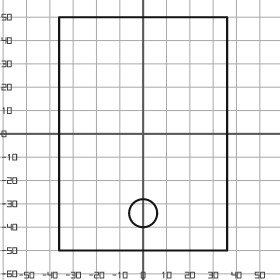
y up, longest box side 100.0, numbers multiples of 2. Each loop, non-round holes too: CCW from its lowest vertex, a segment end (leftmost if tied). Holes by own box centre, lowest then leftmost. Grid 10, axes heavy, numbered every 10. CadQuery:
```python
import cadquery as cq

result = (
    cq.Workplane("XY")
    .moveTo(-36.0, -50.0)
    .lineTo(36.0, -50.0)
    .lineTo(36.0, 50.0)
    .lineTo(-36.0, 50.0)
    .close()
    .moveTo(0.0, -34.0)
    .circle(6.0)
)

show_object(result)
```